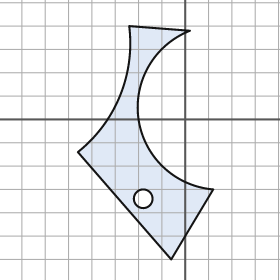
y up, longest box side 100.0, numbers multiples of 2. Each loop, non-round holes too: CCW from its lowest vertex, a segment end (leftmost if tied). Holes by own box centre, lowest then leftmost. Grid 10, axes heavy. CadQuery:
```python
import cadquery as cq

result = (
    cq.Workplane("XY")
    .moveTo(-6.0, -60.0)
    .lineTo(12.0, -30.0)
    .threePointArc((-20.0, 0.0), (2.0, 38.0))
    .lineTo(-24.0, 40.0)
    .threePointArc((-28.0, 10.0), (-46.0, -14.0))
    .close()
    .moveTo(-18.0, -34.0)
    .circle(4.0)
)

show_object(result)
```